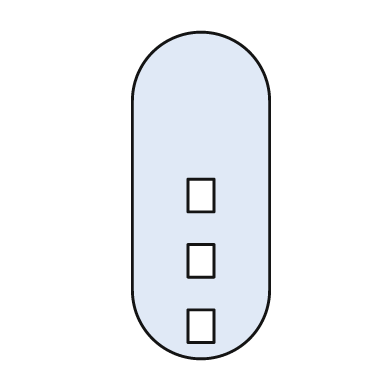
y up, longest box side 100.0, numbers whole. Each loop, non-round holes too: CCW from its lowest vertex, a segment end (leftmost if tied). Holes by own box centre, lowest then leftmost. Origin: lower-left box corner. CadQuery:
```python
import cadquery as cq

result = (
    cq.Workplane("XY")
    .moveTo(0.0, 21.0)
    .threePointArc((21.0, 0.0), (42.0, 21.0))
    .lineTo(42.0, 79.0)
    .threePointArc((21.0, 100.0), (0.0, 79.0))
    .close()
    .moveTo(17.0, 5.0)
    .lineTo(25.0, 5.0)
    .lineTo(25.0, 15.0)
    .lineTo(17.0, 15.0)
    .close()
    .moveTo(17.0, 25.0)
    .lineTo(25.0, 25.0)
    .lineTo(25.0, 35.0)
    .lineTo(17.0, 35.0)
    .close()
    .moveTo(17.0, 45.0)
    .lineTo(25.0, 45.0)
    .lineTo(25.0, 55.0)
    .lineTo(17.0, 55.0)
    .close()
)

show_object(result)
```